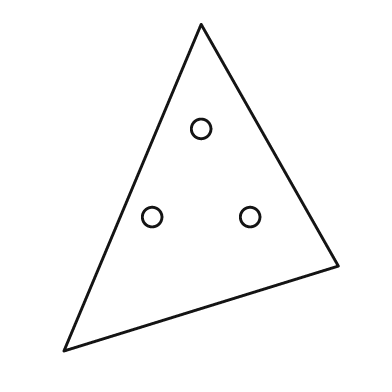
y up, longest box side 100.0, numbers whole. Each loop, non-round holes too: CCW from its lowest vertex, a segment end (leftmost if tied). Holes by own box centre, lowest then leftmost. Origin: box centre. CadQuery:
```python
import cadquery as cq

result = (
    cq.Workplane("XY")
    .moveTo(-42.0, -50.0)
    .lineTo(42.0, -24.0)
    .lineTo(0.0, 50.0)
    .close()
    .moveTo(-15.0, -9.0)
    .circle(3.0)
    .moveTo(15.0, -9.0)
    .circle(3.0)
    .moveTo(0.0, 18.0)
    .circle(3.0)
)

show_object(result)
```